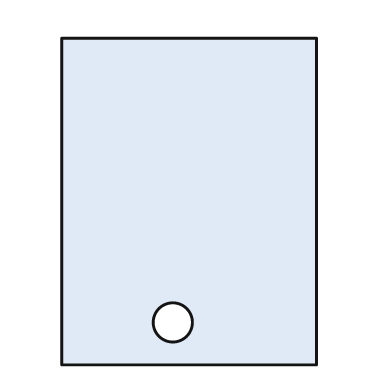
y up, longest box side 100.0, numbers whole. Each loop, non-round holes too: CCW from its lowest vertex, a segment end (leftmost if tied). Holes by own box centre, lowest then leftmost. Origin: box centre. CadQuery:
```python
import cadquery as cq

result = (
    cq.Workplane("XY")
    .moveTo(-39.0, -50.0)
    .lineTo(39.0, -50.0)
    .lineTo(39.0, 50.0)
    .lineTo(-39.0, 50.0)
    .close()
    .moveTo(-5.0, -37.0)
    .circle(6.0)
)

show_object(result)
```